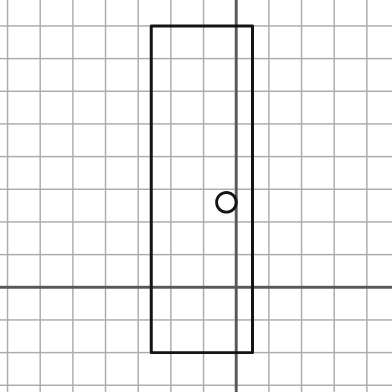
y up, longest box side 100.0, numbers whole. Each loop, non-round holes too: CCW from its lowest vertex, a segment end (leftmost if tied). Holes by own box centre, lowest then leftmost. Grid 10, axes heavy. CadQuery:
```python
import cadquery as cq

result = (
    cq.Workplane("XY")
    .moveTo(-26.0, -20.0)
    .lineTo(5.0, -20.0)
    .lineTo(5.0, 80.0)
    .lineTo(-26.0, 80.0)
    .close()
    .moveTo(-3.0, 26.0)
    .circle(3.0)
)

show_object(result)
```